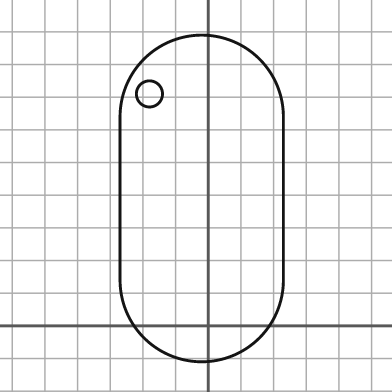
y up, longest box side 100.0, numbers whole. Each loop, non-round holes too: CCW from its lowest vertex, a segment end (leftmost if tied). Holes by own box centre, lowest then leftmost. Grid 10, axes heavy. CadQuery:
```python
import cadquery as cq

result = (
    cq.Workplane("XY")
    .moveTo(-27.0, 14.0)
    .threePointArc((-2.0, -11.0), (23.0, 14.0))
    .lineTo(23.0, 64.0)
    .threePointArc((-2.0, 89.0), (-27.0, 64.0))
    .close()
    .moveTo(-18.0, 71.0)
    .circle(4.0)
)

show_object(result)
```